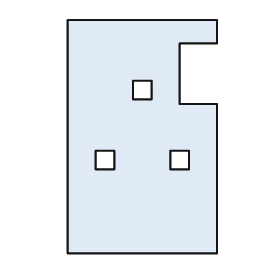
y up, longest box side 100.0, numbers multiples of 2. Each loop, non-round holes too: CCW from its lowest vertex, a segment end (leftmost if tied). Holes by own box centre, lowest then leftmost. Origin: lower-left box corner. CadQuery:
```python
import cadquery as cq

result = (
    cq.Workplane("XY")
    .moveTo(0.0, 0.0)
    .lineTo(64.0, 0.0)
    .lineTo(64.0, 64.0)
    .lineTo(48.0, 64.0)
    .lineTo(48.0, 90.0)
    .lineTo(64.0, 90.0)
    .lineTo(64.0, 100.0)
    .lineTo(0.0, 100.0)
    .close()
    .moveTo(12.0, 36.0)
    .lineTo(20.0, 36.0)
    .lineTo(20.0, 44.0)
    .lineTo(12.0, 44.0)
    .close()
    .moveTo(44.0, 36.0)
    .lineTo(52.0, 36.0)
    .lineTo(52.0, 44.0)
    .lineTo(44.0, 44.0)
    .close()
    .moveTo(28.0, 66.0)
    .lineTo(36.0, 66.0)
    .lineTo(36.0, 74.0)
    .lineTo(28.0, 74.0)
    .close()
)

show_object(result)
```